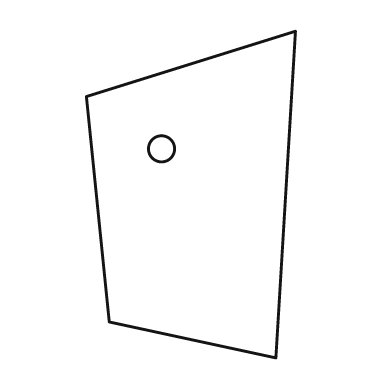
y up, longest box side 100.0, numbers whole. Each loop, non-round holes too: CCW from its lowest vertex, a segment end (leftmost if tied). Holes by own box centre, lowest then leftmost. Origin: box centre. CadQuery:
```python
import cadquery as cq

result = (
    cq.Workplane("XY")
    .moveTo(26.0, -50.0)
    .lineTo(32.0, 50.0)
    .lineTo(-32.0, 30.0)
    .lineTo(-25.0, -39.0)
    .close()
    .moveTo(-9.0, 14.0)
    .circle(4.0)
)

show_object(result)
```